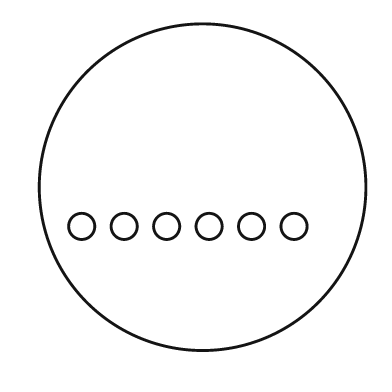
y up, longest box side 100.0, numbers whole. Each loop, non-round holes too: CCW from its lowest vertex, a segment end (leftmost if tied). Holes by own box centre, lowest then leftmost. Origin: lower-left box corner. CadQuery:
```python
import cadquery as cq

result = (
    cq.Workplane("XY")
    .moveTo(50.0, 50.0)
    .circle(50.0)
    .moveTo(13.0, 38.0)
    .circle(4.0)
    .moveTo(26.0, 38.0)
    .circle(4.0)
    .moveTo(39.0, 38.0)
    .circle(4.0)
    .moveTo(52.0, 38.0)
    .circle(4.0)
    .moveTo(65.0, 38.0)
    .circle(4.0)
    .moveTo(78.0, 38.0)
    .circle(4.0)
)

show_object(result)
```